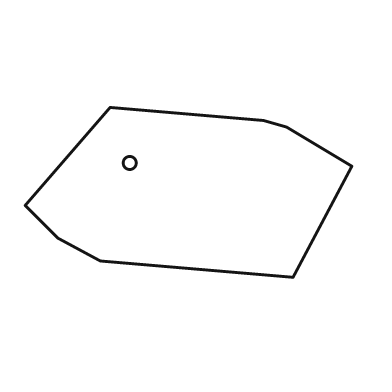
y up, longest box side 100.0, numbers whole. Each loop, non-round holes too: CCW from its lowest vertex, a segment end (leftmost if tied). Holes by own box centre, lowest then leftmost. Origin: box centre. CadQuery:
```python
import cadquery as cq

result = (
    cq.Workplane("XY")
    .moveTo(32.0, -26.0)
    .lineTo(50.0, 8.0)
    .lineTo(30.0, 20.0)
    .lineTo(23.0, 22.0)
    .lineTo(-24.0, 26.0)
    .lineTo(-50.0, -4.0)
    .lineTo(-40.0, -14.0)
    .lineTo(-27.0, -21.0)
    .close()
    .moveTo(-18.0, 9.0)
    .circle(2.0)
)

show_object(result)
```